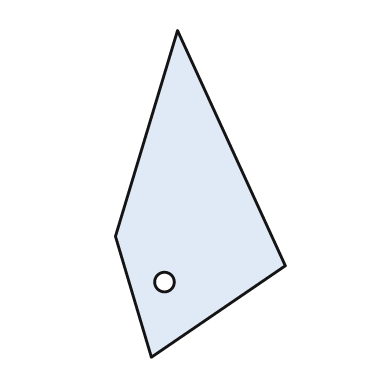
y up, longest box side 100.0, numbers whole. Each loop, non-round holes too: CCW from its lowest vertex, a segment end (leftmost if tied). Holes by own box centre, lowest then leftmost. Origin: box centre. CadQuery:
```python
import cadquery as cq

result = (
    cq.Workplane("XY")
    .moveTo(-15.0, -50.0)
    .lineTo(26.0, -22.0)
    .lineTo(-7.0, 50.0)
    .lineTo(-26.0, -13.0)
    .close()
    .moveTo(-11.0, -27.0)
    .circle(3.0)
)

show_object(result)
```